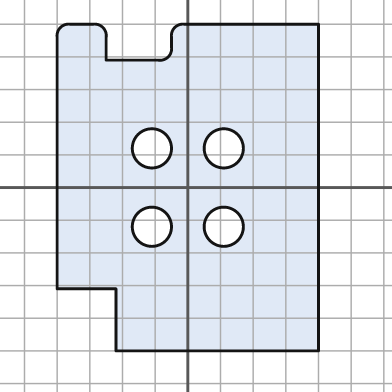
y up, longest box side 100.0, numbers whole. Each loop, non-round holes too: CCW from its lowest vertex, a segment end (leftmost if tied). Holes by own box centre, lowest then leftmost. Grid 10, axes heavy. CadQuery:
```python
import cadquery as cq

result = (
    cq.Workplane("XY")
    .moveTo(-22.0, -50.0)
    .lineTo(40.0, -50.0)
    .lineTo(40.0, 50.0)
    .lineTo(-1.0, 50.0)
    .threePointArc((-4.0, 49.0), (-5.0, 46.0))
    .lineTo(-5.0, 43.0)
    .threePointArc((-6.0, 40.0), (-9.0, 39.0))
    .lineTo(-25.0, 39.0)
    .lineTo(-25.0, 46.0)
    .threePointArc((-26.0, 49.0), (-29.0, 50.0))
    .lineTo(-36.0, 50.0)
    .threePointArc((-39.0, 49.0), (-40.0, 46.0))
    .lineTo(-40.0, -31.0)
    .lineTo(-22.0, -31.0)
    .close()
    .moveTo(-11.0, -12.0)
    .circle(6.0)
    .moveTo(11.0, -12.0)
    .circle(6.0)
    .moveTo(-11.0, 12.0)
    .circle(6.0)
    .moveTo(11.0, 12.0)
    .circle(6.0)
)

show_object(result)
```